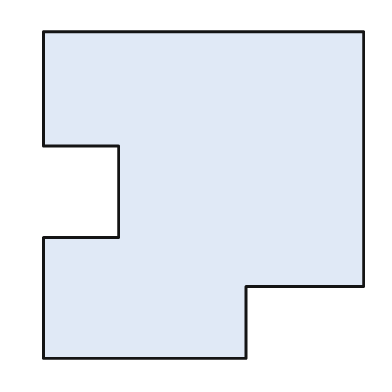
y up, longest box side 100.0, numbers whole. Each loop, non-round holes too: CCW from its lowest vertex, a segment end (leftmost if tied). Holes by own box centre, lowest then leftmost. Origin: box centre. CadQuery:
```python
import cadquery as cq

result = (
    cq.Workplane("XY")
    .moveTo(-49.0, -50.0)
    .lineTo(13.0, -50.0)
    .lineTo(13.0, -28.0)
    .lineTo(49.0, -28.0)
    .lineTo(49.0, 50.0)
    .lineTo(-49.0, 50.0)
    .lineTo(-49.0, 15.0)
    .lineTo(-26.0, 15.0)
    .lineTo(-26.0, -13.0)
    .lineTo(-49.0, -13.0)
    .close()
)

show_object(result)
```